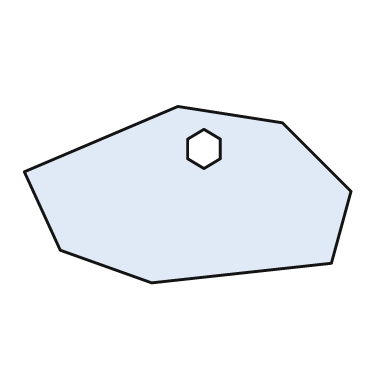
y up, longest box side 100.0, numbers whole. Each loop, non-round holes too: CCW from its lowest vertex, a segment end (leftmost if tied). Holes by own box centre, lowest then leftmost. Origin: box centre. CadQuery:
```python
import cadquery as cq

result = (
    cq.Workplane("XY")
    .moveTo(-11.0, -27.0)
    .lineTo(44.0, -21.0)
    .lineTo(50.0, 1.0)
    .lineTo(29.0, 22.0)
    .lineTo(-3.0, 27.0)
    .lineTo(-50.0, 7.0)
    .lineTo(-39.0, -17.0)
    .close()
    .moveTo(5.0, 8.0)
    .lineTo(10.0, 11.0)
    .lineTo(10.0, 17.0)
    .lineTo(5.0, 20.0)
    .lineTo(0.0, 17.0)
    .lineTo(0.0, 11.0)
    .close()
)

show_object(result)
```